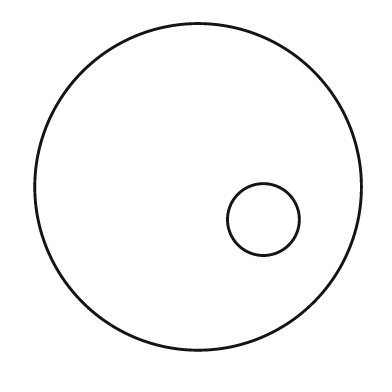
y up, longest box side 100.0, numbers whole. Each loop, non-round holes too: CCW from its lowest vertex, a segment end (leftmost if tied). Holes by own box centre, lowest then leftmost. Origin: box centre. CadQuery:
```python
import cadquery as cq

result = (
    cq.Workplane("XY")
    .moveTo(0.0, 0.0)
    .circle(50.0)
    .moveTo(20.0, -10.0)
    .circle(11.0)
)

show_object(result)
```